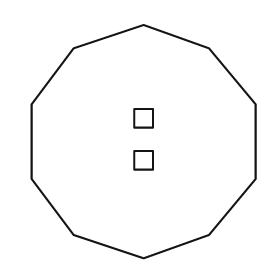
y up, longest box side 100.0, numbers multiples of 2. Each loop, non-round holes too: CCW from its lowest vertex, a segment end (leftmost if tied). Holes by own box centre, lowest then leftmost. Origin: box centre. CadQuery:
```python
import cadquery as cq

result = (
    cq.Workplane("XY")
    .moveTo(0.0, -50.0)
    .lineTo(28.0, -40.0)
    .lineTo(48.0, -16.0)
    .lineTo(48.0, 16.0)
    .lineTo(28.0, 40.0)
    .lineTo(0.0, 50.0)
    .lineTo(-30.0, 40.0)
    .lineTo(-48.0, 16.0)
    .lineTo(-48.0, -16.0)
    .lineTo(-30.0, -40.0)
    .close()
    .moveTo(-4.0, -12.0)
    .lineTo(4.0, -12.0)
    .lineTo(4.0, -4.0)
    .lineTo(-4.0, -4.0)
    .close()
    .moveTo(-4.0, 6.0)
    .lineTo(4.0, 6.0)
    .lineTo(4.0, 14.0)
    .lineTo(-4.0, 14.0)
    .close()
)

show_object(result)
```